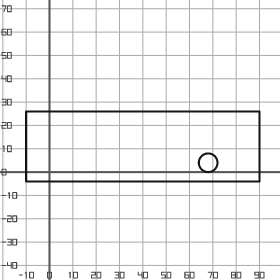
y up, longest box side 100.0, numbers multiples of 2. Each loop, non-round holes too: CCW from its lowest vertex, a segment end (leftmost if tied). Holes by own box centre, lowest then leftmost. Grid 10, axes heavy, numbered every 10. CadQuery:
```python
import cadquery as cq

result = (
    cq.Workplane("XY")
    .moveTo(-10.0, -4.0)
    .lineTo(90.0, -4.0)
    .lineTo(90.0, 26.0)
    .lineTo(-10.0, 26.0)
    .close()
    .moveTo(68.0, 4.0)
    .circle(4.0)
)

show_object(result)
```